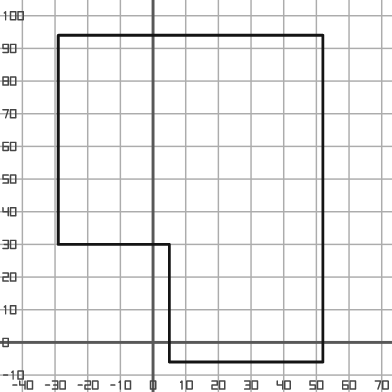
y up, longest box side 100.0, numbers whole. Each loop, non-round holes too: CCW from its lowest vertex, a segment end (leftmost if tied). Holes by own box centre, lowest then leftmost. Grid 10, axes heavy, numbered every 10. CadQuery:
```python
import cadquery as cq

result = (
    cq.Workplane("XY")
    .moveTo(5.0, -6.0)
    .lineTo(52.0, -6.0)
    .lineTo(52.0, 94.0)
    .lineTo(-29.0, 94.0)
    .lineTo(-29.0, 30.0)
    .lineTo(5.0, 30.0)
    .close()
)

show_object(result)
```